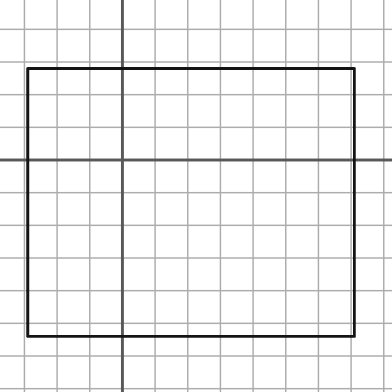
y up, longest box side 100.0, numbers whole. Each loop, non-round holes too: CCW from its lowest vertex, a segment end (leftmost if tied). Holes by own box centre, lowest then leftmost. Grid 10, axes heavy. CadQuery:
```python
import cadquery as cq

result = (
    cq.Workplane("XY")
    .moveTo(-29.0, -54.0)
    .lineTo(71.0, -54.0)
    .lineTo(71.0, 28.0)
    .lineTo(-29.0, 28.0)
    .close()
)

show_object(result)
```